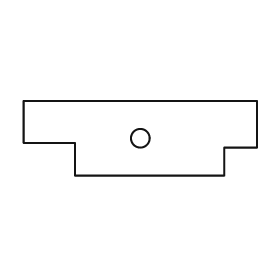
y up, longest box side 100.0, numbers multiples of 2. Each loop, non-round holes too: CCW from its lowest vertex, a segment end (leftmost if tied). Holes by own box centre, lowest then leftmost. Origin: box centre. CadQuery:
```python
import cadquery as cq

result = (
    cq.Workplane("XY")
    .moveTo(-28.0, -16.0)
    .lineTo(36.0, -16.0)
    .lineTo(36.0, -4.0)
    .lineTo(50.0, -4.0)
    .lineTo(50.0, 16.0)
    .lineTo(-50.0, 16.0)
    .lineTo(-50.0, -2.0)
    .lineTo(-28.0, -2.0)
    .close()
    .moveTo(0.0, 0.0)
    .circle(4.0)
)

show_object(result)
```